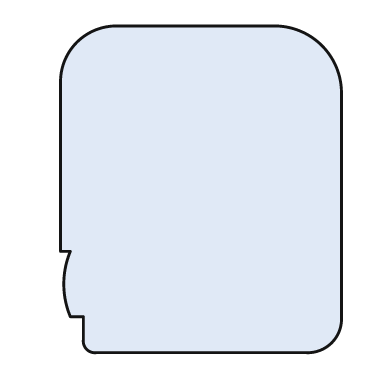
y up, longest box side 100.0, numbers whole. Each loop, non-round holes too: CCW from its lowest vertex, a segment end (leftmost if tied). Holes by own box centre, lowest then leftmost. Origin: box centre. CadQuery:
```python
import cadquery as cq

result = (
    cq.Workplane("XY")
    .moveTo(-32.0, -50.0)
    .lineTo(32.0, -50.0)
    .threePointArc((40.0, -47.0), (43.0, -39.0))
    .lineTo(43.0, 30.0)
    .threePointArc((37.0, 44.0), (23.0, 50.0))
    .lineTo(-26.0, 50.0)
    .threePointArc((-38.0, 45.0), (-43.0, 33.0))
    .lineTo(-43.0, -19.0)
    .lineTo(-40.0, -19.0)
    .threePointArc((-42.0, -29.0), (-40.0, -39.0))
    .lineTo(-36.0, -39.0)
    .lineTo(-36.0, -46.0)
    .threePointArc((-35.0, -49.0), (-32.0, -50.0))
    .close()
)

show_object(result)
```